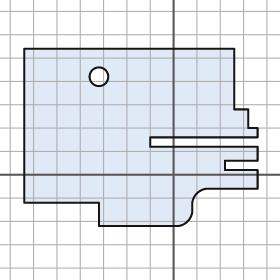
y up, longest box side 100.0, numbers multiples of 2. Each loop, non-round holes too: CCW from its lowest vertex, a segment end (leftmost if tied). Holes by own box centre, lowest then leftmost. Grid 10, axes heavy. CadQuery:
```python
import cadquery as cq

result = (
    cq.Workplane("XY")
    .moveTo(-32.0, -22.0)
    .lineTo(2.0, -22.0)
    .threePointArc((6.0, -20.0), (8.0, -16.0))
    .lineTo(8.0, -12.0)
    .threePointArc((10.0, -8.0), (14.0, -6.0))
    .lineTo(36.0, -6.0)
    .lineTo(36.0, 2.0)
    .lineTo(22.0, 2.0)
    .lineTo(22.0, 6.0)
    .lineTo(36.0, 6.0)
    .lineTo(36.0, 12.0)
    .lineTo(-10.0, 12.0)
    .lineTo(-10.0, 16.0)
    .lineTo(36.0, 16.0)
    .lineTo(36.0, 20.0)
    .lineTo(32.0, 20.0)
    .lineTo(32.0, 28.0)
    .lineTo(26.0, 28.0)
    .lineTo(26.0, 54.0)
    .lineTo(-64.0, 54.0)
    .lineTo(-64.0, -12.0)
    .lineTo(-32.0, -12.0)
    .close()
    .moveTo(-32.0, 42.0)
    .circle(4.0)
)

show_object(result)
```